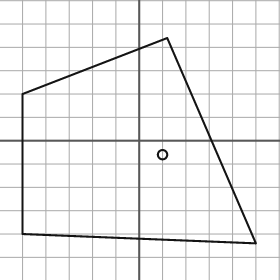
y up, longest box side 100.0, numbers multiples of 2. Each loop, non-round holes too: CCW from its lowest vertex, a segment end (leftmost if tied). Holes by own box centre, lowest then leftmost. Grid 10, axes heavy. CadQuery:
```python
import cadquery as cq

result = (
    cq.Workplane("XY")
    .moveTo(50.0, -44.0)
    .lineTo(12.0, 44.0)
    .lineTo(-50.0, 20.0)
    .lineTo(-50.0, -40.0)
    .close()
    .moveTo(10.0, -6.0)
    .circle(2.0)
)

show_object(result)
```